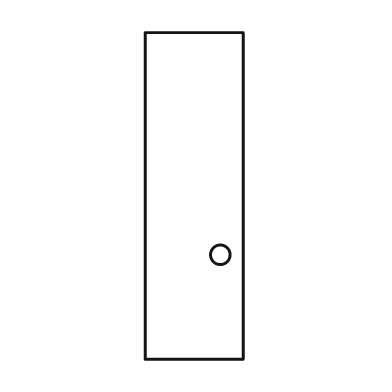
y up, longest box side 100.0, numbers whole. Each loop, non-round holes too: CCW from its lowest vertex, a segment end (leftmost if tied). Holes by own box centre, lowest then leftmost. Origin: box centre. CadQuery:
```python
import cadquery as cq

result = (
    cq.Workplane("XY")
    .moveTo(-15.0, -50.0)
    .lineTo(15.0, -50.0)
    .lineTo(15.0, 50.0)
    .lineTo(-15.0, 50.0)
    .close()
    .moveTo(8.0, -18.0)
    .circle(3.0)
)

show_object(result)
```